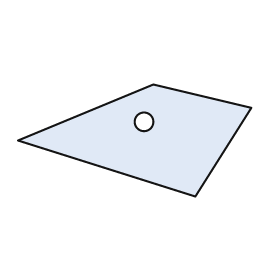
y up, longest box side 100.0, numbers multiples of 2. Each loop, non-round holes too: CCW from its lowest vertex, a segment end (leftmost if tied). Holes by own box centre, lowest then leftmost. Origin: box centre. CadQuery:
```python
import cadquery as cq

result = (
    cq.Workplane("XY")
    .moveTo(26.0, -24.0)
    .lineTo(50.0, 14.0)
    .lineTo(8.0, 24.0)
    .lineTo(-50.0, 0.0)
    .close()
    .moveTo(4.0, 8.0)
    .circle(4.0)
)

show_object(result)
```